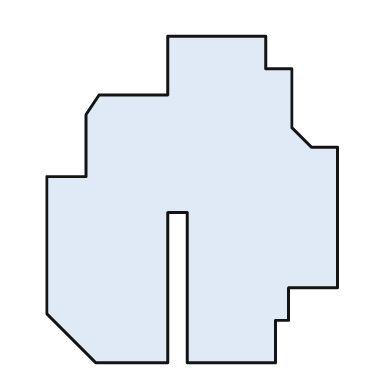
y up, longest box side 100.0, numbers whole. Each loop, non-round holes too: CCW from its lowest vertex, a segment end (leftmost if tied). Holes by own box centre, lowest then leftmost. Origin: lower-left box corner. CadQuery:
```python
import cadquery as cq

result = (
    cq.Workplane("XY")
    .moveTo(15.0, 0.0)
    .lineTo(37.0, 0.0)
    .lineTo(37.0, 46.0)
    .lineTo(43.0, 46.0)
    .lineTo(43.0, 0.0)
    .lineTo(70.0, 0.0)
    .lineTo(70.0, 13.0)
    .lineTo(74.0, 13.0)
    .lineTo(74.0, 23.0)
    .lineTo(89.0, 23.0)
    .lineTo(89.0, 66.0)
    .lineTo(81.0, 66.0)
    .lineTo(75.0, 72.0)
    .lineTo(75.0, 90.0)
    .lineTo(67.0, 90.0)
    .lineTo(67.0, 100.0)
    .lineTo(37.0, 100.0)
    .lineTo(37.0, 82.0)
    .lineTo(16.0, 82.0)
    .lineTo(12.0, 76.0)
    .lineTo(12.0, 57.0)
    .lineTo(0.0, 57.0)
    .lineTo(0.0, 15.0)
    .close()
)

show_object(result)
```